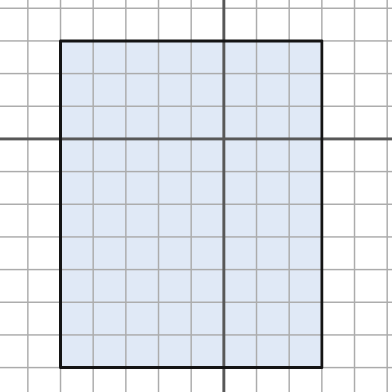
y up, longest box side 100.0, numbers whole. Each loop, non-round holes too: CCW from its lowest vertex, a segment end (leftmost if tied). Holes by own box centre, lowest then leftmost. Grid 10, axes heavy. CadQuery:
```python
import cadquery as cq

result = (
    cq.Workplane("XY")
    .moveTo(-50.0, -70.0)
    .lineTo(30.0, -70.0)
    .lineTo(30.0, 30.0)
    .lineTo(-50.0, 30.0)
    .close()
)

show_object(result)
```